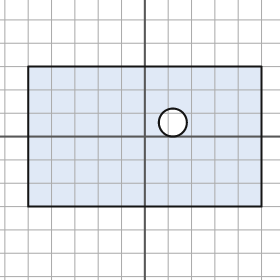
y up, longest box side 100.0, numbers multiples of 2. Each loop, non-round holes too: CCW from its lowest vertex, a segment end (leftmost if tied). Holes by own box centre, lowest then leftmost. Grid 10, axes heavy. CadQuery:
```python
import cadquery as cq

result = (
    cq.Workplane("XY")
    .moveTo(-50.0, -30.0)
    .lineTo(50.0, -30.0)
    .lineTo(50.0, 30.0)
    .lineTo(-50.0, 30.0)
    .close()
    .moveTo(12.0, 6.0)
    .circle(6.0)
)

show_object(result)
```